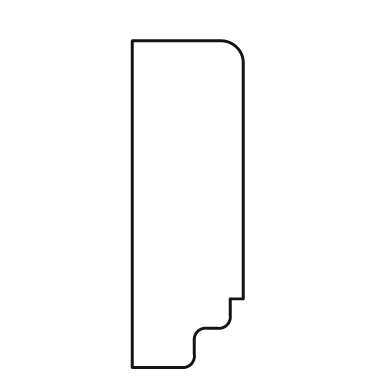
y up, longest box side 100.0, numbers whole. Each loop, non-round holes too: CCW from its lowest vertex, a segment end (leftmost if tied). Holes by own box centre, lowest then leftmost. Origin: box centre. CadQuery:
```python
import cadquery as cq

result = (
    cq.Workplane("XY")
    .moveTo(-17.0, -50.0)
    .lineTo(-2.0, -50.0)
    .threePointArc((1.0, -49.0), (2.0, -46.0))
    .lineTo(2.0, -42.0)
    .threePointArc((3.0, -39.0), (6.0, -38.0))
    .lineTo(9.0, -38.0)
    .threePointArc((12.0, -37.0), (13.0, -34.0))
    .lineTo(13.0, -29.0)
    .lineTo(17.0, -29.0)
    .lineTo(17.0, 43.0)
    .threePointArc((15.0, 48.0), (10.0, 50.0))
    .lineTo(-17.0, 50.0)
    .close()
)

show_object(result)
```